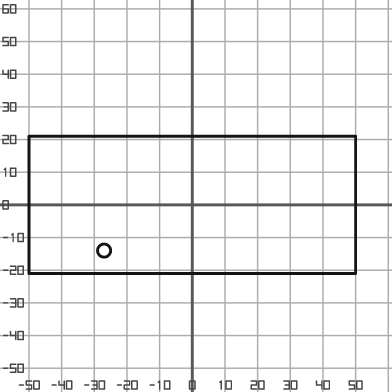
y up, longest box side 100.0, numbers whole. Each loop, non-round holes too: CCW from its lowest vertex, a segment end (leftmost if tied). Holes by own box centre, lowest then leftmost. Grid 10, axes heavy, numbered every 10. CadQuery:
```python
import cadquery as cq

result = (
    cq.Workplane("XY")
    .moveTo(-50.0, -21.0)
    .lineTo(50.0, -21.0)
    .lineTo(50.0, 21.0)
    .lineTo(-50.0, 21.0)
    .close()
    .moveTo(-27.0, -14.0)
    .circle(2.0)
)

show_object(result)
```